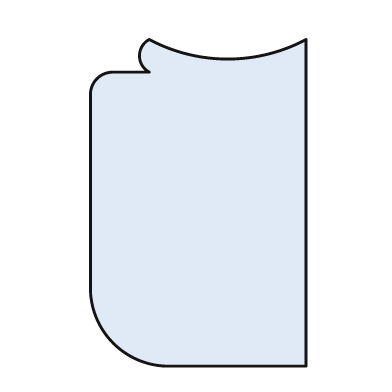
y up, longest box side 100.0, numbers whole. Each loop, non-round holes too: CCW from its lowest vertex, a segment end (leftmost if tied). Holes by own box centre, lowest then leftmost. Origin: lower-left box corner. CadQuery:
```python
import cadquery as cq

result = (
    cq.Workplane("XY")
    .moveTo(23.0, 0.0)
    .lineTo(66.0, 0.0)
    .lineTo(66.0, 100.0)
    .threePointArc((42.0, 94.0), (18.0, 100.0))
    .threePointArc((15.0, 95.0), (18.0, 90.0))
    .lineTo(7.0, 90.0)
    .threePointArc((2.0, 88.0), (0.0, 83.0))
    .lineTo(0.0, 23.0)
    .threePointArc((7.0, 7.0), (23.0, 0.0))
    .close()
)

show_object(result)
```